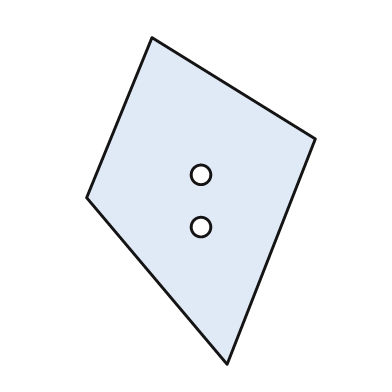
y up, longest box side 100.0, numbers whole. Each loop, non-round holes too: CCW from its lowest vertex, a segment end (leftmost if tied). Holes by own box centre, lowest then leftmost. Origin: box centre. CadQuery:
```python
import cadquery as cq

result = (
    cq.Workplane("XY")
    .moveTo(8.0, -50.0)
    .lineTo(35.0, 19.0)
    .lineTo(-15.0, 50.0)
    .lineTo(-35.0, 1.0)
    .close()
    .moveTo(0.0, -8.0)
    .circle(3.0)
    .moveTo(0.0, 8.0)
    .circle(3.0)
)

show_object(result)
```